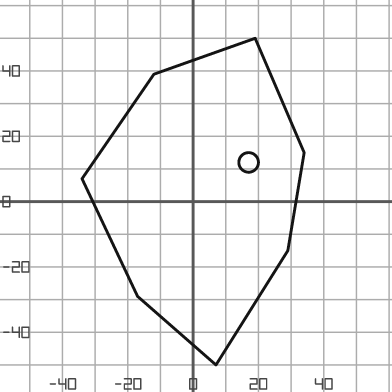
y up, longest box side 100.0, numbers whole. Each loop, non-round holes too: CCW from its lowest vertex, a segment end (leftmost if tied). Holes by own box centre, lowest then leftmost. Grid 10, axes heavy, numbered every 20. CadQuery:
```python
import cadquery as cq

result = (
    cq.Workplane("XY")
    .moveTo(7.0, -50.0)
    .lineTo(29.0, -15.0)
    .lineTo(34.0, 15.0)
    .lineTo(19.0, 50.0)
    .lineTo(-12.0, 39.0)
    .lineTo(-34.0, 7.0)
    .lineTo(-17.0, -29.0)
    .close()
    .moveTo(17.0, 12.0)
    .circle(3.0)
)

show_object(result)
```